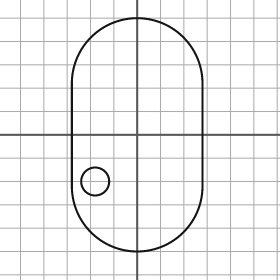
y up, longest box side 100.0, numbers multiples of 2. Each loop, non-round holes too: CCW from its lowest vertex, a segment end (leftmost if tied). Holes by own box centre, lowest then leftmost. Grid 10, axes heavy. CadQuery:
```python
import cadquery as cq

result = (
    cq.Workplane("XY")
    .moveTo(-28.0, -22.0)
    .threePointArc((0.0, -50.0), (28.0, -22.0))
    .lineTo(28.0, 22.0)
    .threePointArc((0.0, 50.0), (-28.0, 22.0))
    .close()
    .moveTo(-18.0, -20.0)
    .circle(6.0)
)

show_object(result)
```